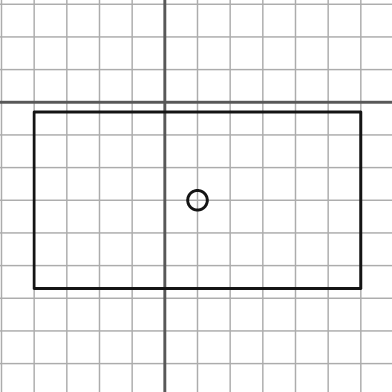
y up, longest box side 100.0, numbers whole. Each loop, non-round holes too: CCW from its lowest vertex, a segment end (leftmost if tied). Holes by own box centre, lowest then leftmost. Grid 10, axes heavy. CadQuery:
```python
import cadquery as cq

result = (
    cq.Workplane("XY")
    .moveTo(-40.0, -57.0)
    .lineTo(60.0, -57.0)
    .lineTo(60.0, -3.0)
    .lineTo(-40.0, -3.0)
    .close()
    .moveTo(10.0, -30.0)
    .circle(3.0)
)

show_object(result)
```